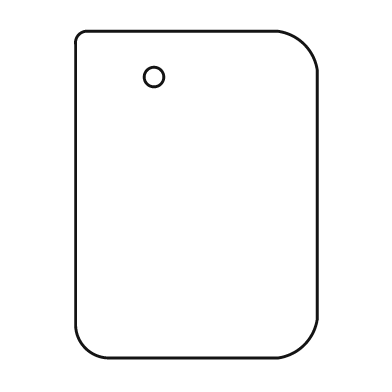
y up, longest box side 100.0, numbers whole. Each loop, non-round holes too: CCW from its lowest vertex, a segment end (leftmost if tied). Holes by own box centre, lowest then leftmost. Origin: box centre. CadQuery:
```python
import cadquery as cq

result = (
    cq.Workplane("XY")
    .moveTo(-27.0, -50.0)
    .lineTo(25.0, -50.0)
    .threePointArc((33.0, -46.0), (37.0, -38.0))
    .lineTo(37.0, 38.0)
    .threePointArc((33.0, 46.0), (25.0, 50.0))
    .lineTo(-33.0, 50.0)
    .threePointArc((-36.0, 49.0), (-37.0, 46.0))
    .lineTo(-37.0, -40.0)
    .threePointArc((-34.0, -47.0), (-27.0, -50.0))
    .close()
    .moveTo(-13.0, 36.0)
    .circle(3.0)
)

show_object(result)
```